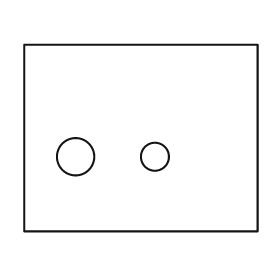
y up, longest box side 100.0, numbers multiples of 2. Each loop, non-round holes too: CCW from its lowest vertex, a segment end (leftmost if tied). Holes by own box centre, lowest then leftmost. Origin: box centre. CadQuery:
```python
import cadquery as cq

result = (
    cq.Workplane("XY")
    .moveTo(-50.0, -40.0)
    .lineTo(50.0, -40.0)
    .lineTo(50.0, 40.0)
    .lineTo(-50.0, 40.0)
    .close()
    .moveTo(-28.0, -8.0)
    .circle(8.0)
    .moveTo(6.0, -8.0)
    .circle(6.0)
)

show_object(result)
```